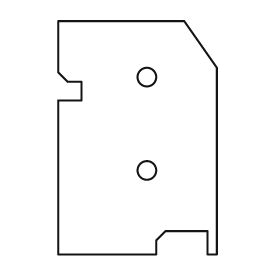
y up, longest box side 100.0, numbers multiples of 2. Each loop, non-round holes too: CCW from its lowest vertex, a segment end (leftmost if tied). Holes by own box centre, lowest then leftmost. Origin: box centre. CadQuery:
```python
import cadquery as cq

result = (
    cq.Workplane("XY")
    .moveTo(-34.0, -50.0)
    .lineTo(8.0, -50.0)
    .lineTo(8.0, -44.0)
    .lineTo(12.0, -40.0)
    .lineTo(30.0, -40.0)
    .lineTo(30.0, -50.0)
    .lineTo(34.0, -50.0)
    .lineTo(34.0, 30.0)
    .lineTo(20.0, 50.0)
    .lineTo(-34.0, 50.0)
    .lineTo(-34.0, 28.0)
    .lineTo(-30.0, 24.0)
    .lineTo(-24.0, 24.0)
    .lineTo(-24.0, 16.0)
    .lineTo(-34.0, 16.0)
    .close()
    .moveTo(4.0, -14.0)
    .circle(4.0)
    .moveTo(4.0, 26.0)
    .circle(4.0)
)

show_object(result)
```